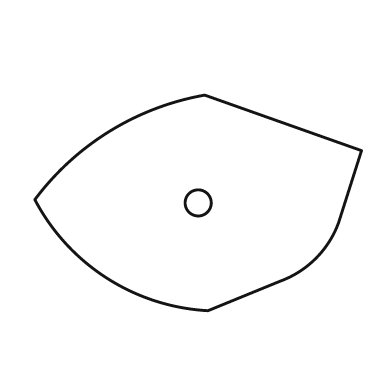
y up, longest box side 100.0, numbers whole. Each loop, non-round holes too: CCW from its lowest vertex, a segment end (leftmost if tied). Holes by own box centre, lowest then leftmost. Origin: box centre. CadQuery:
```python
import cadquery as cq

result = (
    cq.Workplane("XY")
    .moveTo(3.0, -33.0)
    .lineTo(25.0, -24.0)
    .threePointArc((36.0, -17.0), (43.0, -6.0))
    .lineTo(50.0, 16.0)
    .lineTo(2.0, 33.0)
    .threePointArc((-27.0, 22.0), (-50.0, 1.0))
    .threePointArc((-28.0, -23.0), (3.0, -33.0))
    .close()
    .moveTo(0.0, 0.0)
    .circle(4.0)
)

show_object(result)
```